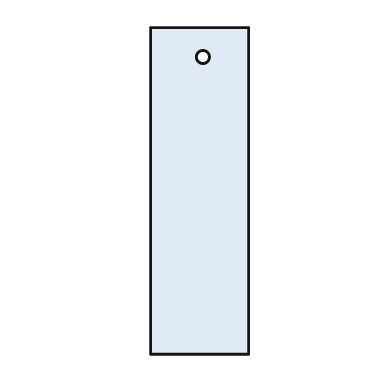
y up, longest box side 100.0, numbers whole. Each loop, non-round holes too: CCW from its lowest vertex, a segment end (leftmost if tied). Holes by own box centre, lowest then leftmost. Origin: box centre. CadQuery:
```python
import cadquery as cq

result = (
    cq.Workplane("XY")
    .moveTo(-15.0, -50.0)
    .lineTo(15.0, -50.0)
    .lineTo(15.0, 50.0)
    .lineTo(-15.0, 50.0)
    .close()
    .moveTo(1.0, 41.0)
    .circle(2.0)
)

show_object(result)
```